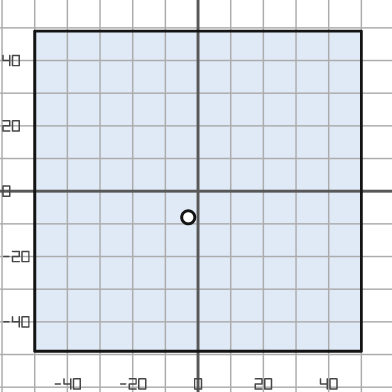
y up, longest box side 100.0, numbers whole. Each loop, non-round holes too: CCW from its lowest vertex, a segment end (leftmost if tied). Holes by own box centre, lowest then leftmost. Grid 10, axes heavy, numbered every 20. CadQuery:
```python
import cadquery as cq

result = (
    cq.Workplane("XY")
    .moveTo(-50.0, -49.0)
    .lineTo(50.0, -49.0)
    .lineTo(50.0, 49.0)
    .lineTo(-50.0, 49.0)
    .close()
    .moveTo(-3.0, -8.0)
    .circle(2.0)
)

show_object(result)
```